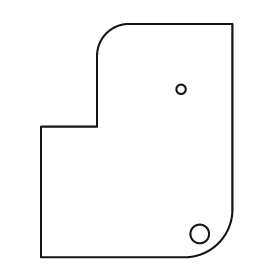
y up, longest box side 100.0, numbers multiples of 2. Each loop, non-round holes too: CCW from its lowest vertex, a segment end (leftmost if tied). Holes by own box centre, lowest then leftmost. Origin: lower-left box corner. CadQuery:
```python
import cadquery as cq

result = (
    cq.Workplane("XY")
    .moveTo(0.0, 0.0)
    .lineTo(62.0, 0.0)
    .threePointArc((76.0, 6.0), (82.0, 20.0))
    .lineTo(82.0, 100.0)
    .lineTo(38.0, 100.0)
    .threePointArc((28.0, 96.0), (24.0, 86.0))
    .lineTo(24.0, 56.0)
    .lineTo(0.0, 56.0)
    .close()
    .moveTo(68.0, 10.0)
    .circle(4.0)
    .moveTo(60.0, 72.0)
    .circle(2.0)
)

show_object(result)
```